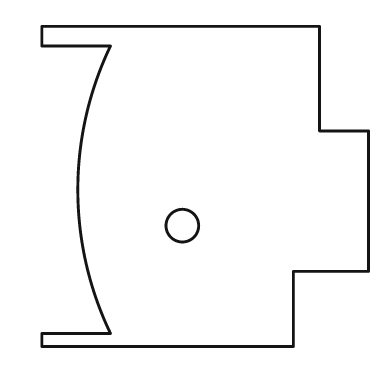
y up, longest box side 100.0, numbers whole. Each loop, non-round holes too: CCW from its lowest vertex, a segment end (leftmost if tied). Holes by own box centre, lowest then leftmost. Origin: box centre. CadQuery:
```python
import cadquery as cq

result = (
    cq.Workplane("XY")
    .moveTo(-50.0, -49.0)
    .lineTo(27.0, -49.0)
    .lineTo(27.0, -26.0)
    .lineTo(50.0, -26.0)
    .lineTo(50.0, 17.0)
    .lineTo(35.0, 17.0)
    .lineTo(35.0, 49.0)
    .lineTo(-50.0, 49.0)
    .lineTo(-50.0, 43.0)
    .lineTo(-29.0, 43.0)
    .threePointArc((-39.0, -1.0), (-29.0, -45.0))
    .lineTo(-50.0, -45.0)
    .close()
    .moveTo(-7.0, -12.0)
    .circle(5.0)
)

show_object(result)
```